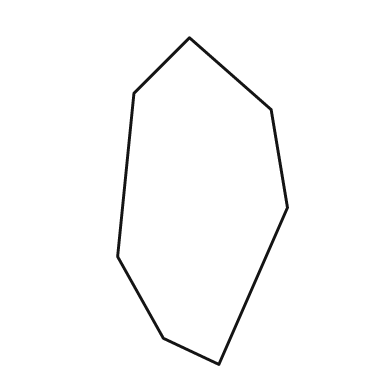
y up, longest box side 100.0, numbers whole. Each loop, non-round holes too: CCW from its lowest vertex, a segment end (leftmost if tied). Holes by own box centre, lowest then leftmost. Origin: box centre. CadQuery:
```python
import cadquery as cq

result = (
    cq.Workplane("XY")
    .moveTo(5.0, -50.0)
    .lineTo(26.0, -2.0)
    .lineTo(21.0, 28.0)
    .lineTo(-4.0, 50.0)
    .lineTo(-21.0, 33.0)
    .lineTo(-26.0, -17.0)
    .lineTo(-12.0, -42.0)
    .close()
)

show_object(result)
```